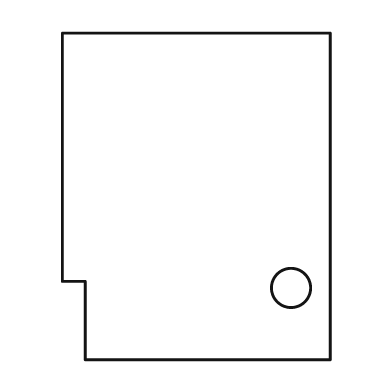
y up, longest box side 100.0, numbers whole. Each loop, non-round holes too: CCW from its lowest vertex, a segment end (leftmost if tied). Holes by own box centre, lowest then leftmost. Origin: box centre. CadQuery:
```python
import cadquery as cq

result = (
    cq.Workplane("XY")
    .moveTo(-34.0, -50.0)
    .lineTo(41.0, -50.0)
    .lineTo(41.0, 50.0)
    .lineTo(-41.0, 50.0)
    .lineTo(-41.0, -26.0)
    .lineTo(-34.0, -26.0)
    .close()
    .moveTo(29.0, -28.0)
    .circle(6.0)
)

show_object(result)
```